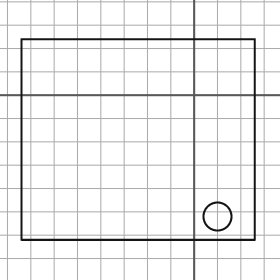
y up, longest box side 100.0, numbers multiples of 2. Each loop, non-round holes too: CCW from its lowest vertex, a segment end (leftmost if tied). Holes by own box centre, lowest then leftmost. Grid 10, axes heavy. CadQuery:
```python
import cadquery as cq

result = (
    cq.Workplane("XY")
    .moveTo(-74.0, -62.0)
    .lineTo(26.0, -62.0)
    .lineTo(26.0, 24.0)
    .lineTo(-74.0, 24.0)
    .close()
    .moveTo(10.0, -52.0)
    .circle(6.0)
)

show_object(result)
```